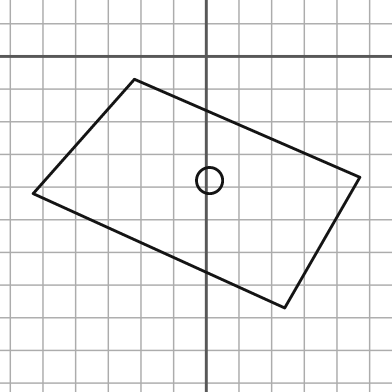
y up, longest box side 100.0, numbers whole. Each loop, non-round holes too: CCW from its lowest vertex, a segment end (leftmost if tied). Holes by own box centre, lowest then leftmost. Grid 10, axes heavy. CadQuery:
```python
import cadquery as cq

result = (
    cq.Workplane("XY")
    .moveTo(24.0, -77.0)
    .lineTo(47.0, -37.0)
    .lineTo(-22.0, -7.0)
    .lineTo(-53.0, -42.0)
    .close()
    .moveTo(1.0, -38.0)
    .circle(4.0)
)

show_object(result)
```